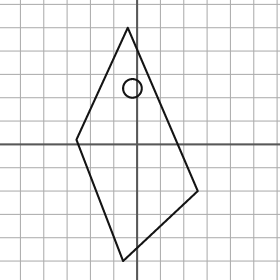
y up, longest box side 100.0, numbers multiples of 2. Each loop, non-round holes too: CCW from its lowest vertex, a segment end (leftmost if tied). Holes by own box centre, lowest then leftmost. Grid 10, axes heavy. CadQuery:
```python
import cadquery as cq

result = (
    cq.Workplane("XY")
    .moveTo(-6.0, -50.0)
    .lineTo(26.0, -20.0)
    .lineTo(-4.0, 50.0)
    .lineTo(-26.0, 2.0)
    .close()
    .moveTo(-2.0, 24.0)
    .circle(4.0)
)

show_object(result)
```